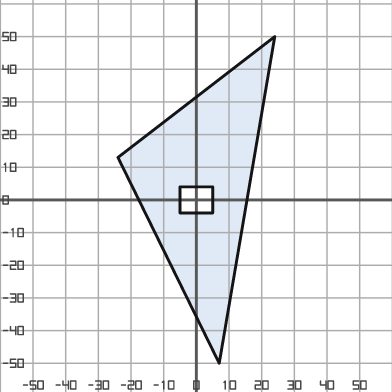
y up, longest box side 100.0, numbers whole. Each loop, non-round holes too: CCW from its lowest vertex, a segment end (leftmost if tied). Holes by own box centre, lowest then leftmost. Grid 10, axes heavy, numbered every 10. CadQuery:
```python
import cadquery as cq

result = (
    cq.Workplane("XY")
    .moveTo(7.0, -50.0)
    .lineTo(24.0, 50.0)
    .lineTo(-24.0, 13.0)
    .close()
    .moveTo(-5.0, -4.0)
    .lineTo(5.0, -4.0)
    .lineTo(5.0, 4.0)
    .lineTo(-5.0, 4.0)
    .close()
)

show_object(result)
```